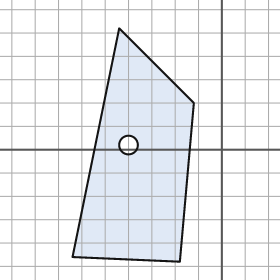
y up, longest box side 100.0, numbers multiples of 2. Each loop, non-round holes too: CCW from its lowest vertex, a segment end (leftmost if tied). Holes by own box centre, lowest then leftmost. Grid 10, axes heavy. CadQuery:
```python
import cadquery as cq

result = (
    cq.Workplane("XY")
    .moveTo(-18.0, -48.0)
    .lineTo(-12.0, 20.0)
    .lineTo(-44.0, 52.0)
    .lineTo(-64.0, -46.0)
    .close()
    .moveTo(-40.0, 2.0)
    .circle(4.0)
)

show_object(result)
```